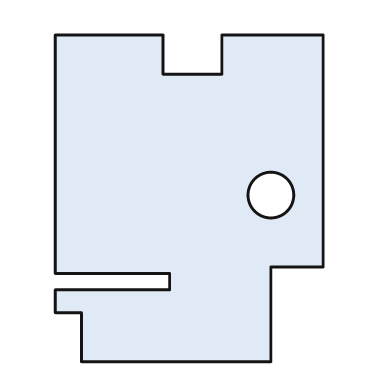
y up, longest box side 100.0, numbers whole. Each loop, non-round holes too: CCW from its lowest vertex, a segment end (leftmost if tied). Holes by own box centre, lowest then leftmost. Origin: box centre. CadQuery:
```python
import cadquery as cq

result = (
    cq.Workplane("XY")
    .moveTo(-33.0, -50.0)
    .lineTo(25.0, -50.0)
    .lineTo(25.0, -21.0)
    .lineTo(41.0, -21.0)
    .lineTo(41.0, 50.0)
    .lineTo(10.0, 50.0)
    .lineTo(10.0, 38.0)
    .lineTo(-8.0, 38.0)
    .lineTo(-8.0, 50.0)
    .lineTo(-41.0, 50.0)
    .lineTo(-41.0, -23.0)
    .lineTo(-6.0, -23.0)
    .lineTo(-6.0, -28.0)
    .lineTo(-41.0, -28.0)
    .lineTo(-41.0, -35.0)
    .lineTo(-33.0, -35.0)
    .close()
    .moveTo(25.0, 1.0)
    .circle(7.0)
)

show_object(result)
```